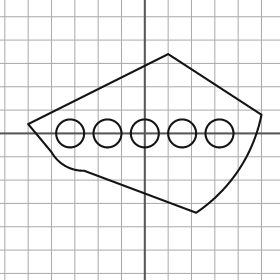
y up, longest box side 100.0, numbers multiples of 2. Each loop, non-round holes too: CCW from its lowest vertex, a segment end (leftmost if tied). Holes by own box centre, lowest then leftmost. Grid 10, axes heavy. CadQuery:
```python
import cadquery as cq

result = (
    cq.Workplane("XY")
    .moveTo(22.0, -34.0)
    .threePointArc((40.0, -16.0), (50.0, 8.0))
    .lineTo(10.0, 34.0)
    .lineTo(-50.0, 4.0)
    .lineTo(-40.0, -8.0)
    .threePointArc((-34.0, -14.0), (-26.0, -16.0))
    .close()
    .moveTo(-32.0, 0.0)
    .circle(6.0)
    .moveTo(-16.0, 0.0)
    .circle(6.0)
    .moveTo(0.0, 0.0)
    .circle(6.0)
    .moveTo(16.0, 0.0)
    .circle(6.0)
    .moveTo(32.0, 0.0)
    .circle(6.0)
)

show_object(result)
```